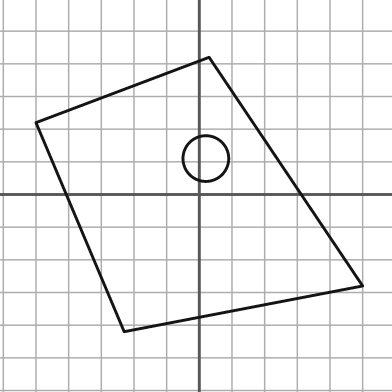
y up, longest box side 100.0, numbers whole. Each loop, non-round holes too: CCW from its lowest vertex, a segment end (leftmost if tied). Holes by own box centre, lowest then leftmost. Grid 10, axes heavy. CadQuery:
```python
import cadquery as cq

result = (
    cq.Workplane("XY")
    .moveTo(-23.0, -42.0)
    .lineTo(50.0, -28.0)
    .lineTo(3.0, 42.0)
    .lineTo(-50.0, 22.0)
    .close()
    .moveTo(2.0, 11.0)
    .circle(7.0)
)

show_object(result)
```